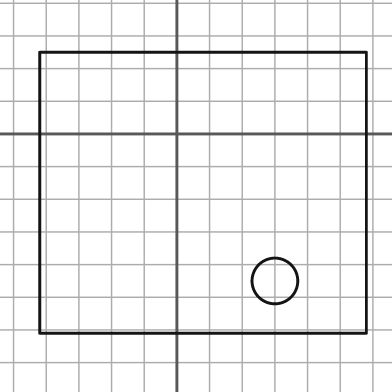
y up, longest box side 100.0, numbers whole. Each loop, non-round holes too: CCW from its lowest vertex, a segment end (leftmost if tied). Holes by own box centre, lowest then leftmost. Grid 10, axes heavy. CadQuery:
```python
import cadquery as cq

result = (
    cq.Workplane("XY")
    .moveTo(-42.0, -61.0)
    .lineTo(58.0, -61.0)
    .lineTo(58.0, 25.0)
    .lineTo(-42.0, 25.0)
    .close()
    .moveTo(30.0, -45.0)
    .circle(7.0)
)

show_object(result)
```